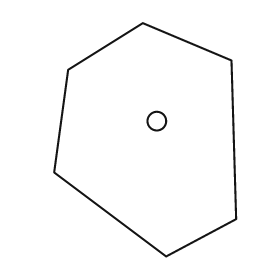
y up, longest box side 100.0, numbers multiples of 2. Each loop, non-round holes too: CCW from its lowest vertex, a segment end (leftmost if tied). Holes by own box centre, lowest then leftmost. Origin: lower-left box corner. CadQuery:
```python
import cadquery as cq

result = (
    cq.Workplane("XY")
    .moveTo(48.0, 0.0)
    .lineTo(78.0, 16.0)
    .lineTo(76.0, 84.0)
    .lineTo(38.0, 100.0)
    .lineTo(6.0, 80.0)
    .lineTo(0.0, 36.0)
    .close()
    .moveTo(44.0, 58.0)
    .circle(4.0)
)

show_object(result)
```